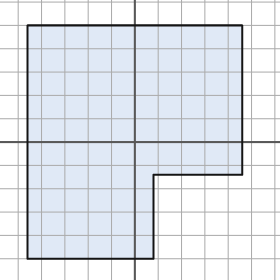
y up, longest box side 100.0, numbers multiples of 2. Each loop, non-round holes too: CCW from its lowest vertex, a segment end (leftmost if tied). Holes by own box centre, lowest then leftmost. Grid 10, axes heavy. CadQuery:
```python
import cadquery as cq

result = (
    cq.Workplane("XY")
    .moveTo(-46.0, -50.0)
    .lineTo(8.0, -50.0)
    .lineTo(8.0, -14.0)
    .lineTo(46.0, -14.0)
    .lineTo(46.0, 50.0)
    .lineTo(-46.0, 50.0)
    .close()
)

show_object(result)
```